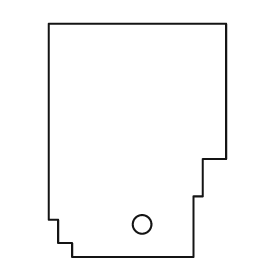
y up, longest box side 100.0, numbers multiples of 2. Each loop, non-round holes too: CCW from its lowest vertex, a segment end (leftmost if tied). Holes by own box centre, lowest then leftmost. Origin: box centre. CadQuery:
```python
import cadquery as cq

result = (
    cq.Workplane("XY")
    .moveTo(-28.0, -50.0)
    .lineTo(24.0, -50.0)
    .lineTo(24.0, -24.0)
    .lineTo(28.0, -24.0)
    .lineTo(28.0, -8.0)
    .lineTo(38.0, -8.0)
    .lineTo(38.0, 50.0)
    .lineTo(-38.0, 50.0)
    .lineTo(-38.0, -34.0)
    .lineTo(-34.0, -34.0)
    .lineTo(-34.0, -44.0)
    .lineTo(-28.0, -44.0)
    .close()
    .moveTo(2.0, -36.0)
    .circle(4.0)
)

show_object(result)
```